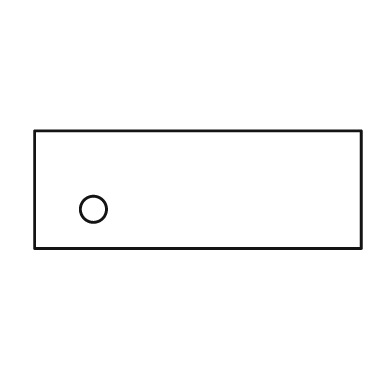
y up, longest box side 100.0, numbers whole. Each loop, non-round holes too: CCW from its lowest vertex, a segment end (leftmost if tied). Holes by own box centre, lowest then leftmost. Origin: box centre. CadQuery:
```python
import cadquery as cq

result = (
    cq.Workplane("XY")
    .moveTo(-50.0, -18.0)
    .lineTo(50.0, -18.0)
    .lineTo(50.0, 18.0)
    .lineTo(-50.0, 18.0)
    .close()
    .moveTo(-32.0, -6.0)
    .circle(4.0)
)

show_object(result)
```